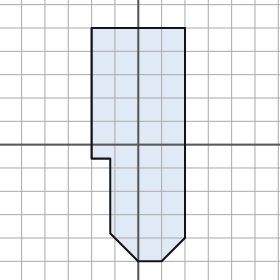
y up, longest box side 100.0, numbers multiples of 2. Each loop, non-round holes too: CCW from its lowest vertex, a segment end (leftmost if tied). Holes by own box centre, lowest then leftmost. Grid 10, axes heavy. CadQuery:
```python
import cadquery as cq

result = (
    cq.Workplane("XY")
    .moveTo(0.0, -50.0)
    .lineTo(10.0, -50.0)
    .lineTo(20.0, -40.0)
    .lineTo(20.0, 50.0)
    .lineTo(-20.0, 50.0)
    .lineTo(-20.0, -6.0)
    .lineTo(-12.0, -6.0)
    .lineTo(-12.0, -38.0)
    .close()
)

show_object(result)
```